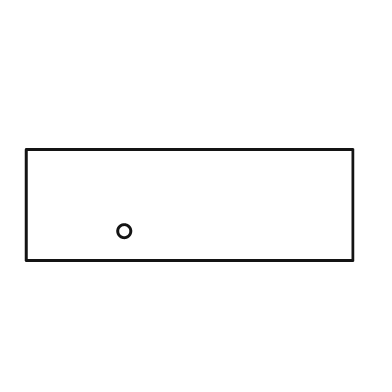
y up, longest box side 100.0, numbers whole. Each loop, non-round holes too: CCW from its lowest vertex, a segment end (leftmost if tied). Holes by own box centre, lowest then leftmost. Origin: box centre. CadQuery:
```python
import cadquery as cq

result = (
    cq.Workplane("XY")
    .moveTo(-50.0, -17.0)
    .lineTo(50.0, -17.0)
    .lineTo(50.0, 17.0)
    .lineTo(-50.0, 17.0)
    .close()
    .moveTo(-20.0, -8.0)
    .circle(2.0)
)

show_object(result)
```